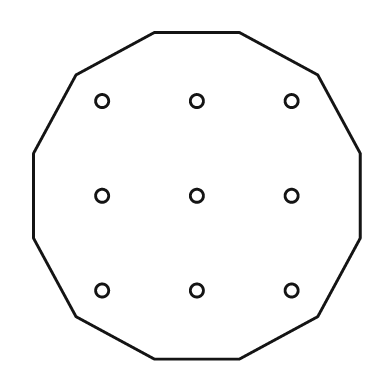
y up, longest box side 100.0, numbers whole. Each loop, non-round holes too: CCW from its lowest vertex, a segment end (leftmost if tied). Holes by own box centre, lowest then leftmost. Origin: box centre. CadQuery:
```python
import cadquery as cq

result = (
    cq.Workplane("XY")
    .moveTo(-13.0, -50.0)
    .lineTo(13.0, -50.0)
    .lineTo(37.0, -37.0)
    .lineTo(50.0, -13.0)
    .lineTo(50.0, 13.0)
    .lineTo(37.0, 37.0)
    .lineTo(13.0, 50.0)
    .lineTo(-13.0, 50.0)
    .lineTo(-37.0, 37.0)
    .lineTo(-50.0, 13.0)
    .lineTo(-50.0, -13.0)
    .lineTo(-37.0, -37.0)
    .close()
    .moveTo(-29.0, -29.0)
    .circle(2.0)
    .moveTo(0.0, -29.0)
    .circle(2.0)
    .moveTo(29.0, -29.0)
    .circle(2.0)
    .moveTo(-29.0, 0.0)
    .circle(2.0)
    .moveTo(0.0, 0.0)
    .circle(2.0)
    .moveTo(29.0, 0.0)
    .circle(2.0)
    .moveTo(-29.0, 29.0)
    .circle(2.0)
    .moveTo(0.0, 29.0)
    .circle(2.0)
    .moveTo(29.0, 29.0)
    .circle(2.0)
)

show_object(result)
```